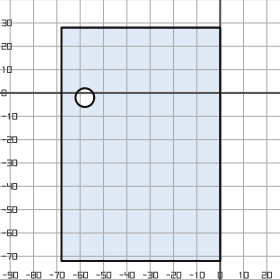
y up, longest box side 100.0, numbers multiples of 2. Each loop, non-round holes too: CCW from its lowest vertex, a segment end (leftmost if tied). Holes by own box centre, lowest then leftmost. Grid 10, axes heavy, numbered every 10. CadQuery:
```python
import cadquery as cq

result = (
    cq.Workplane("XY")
    .moveTo(-68.0, -72.0)
    .lineTo(0.0, -72.0)
    .lineTo(0.0, 28.0)
    .lineTo(-68.0, 28.0)
    .close()
    .moveTo(-58.0, -2.0)
    .circle(4.0)
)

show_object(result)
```